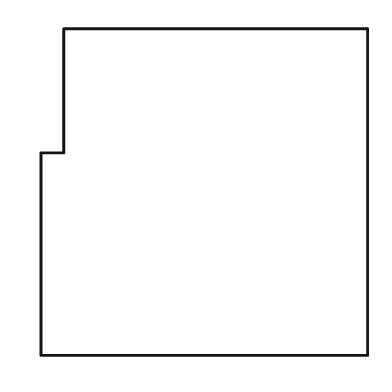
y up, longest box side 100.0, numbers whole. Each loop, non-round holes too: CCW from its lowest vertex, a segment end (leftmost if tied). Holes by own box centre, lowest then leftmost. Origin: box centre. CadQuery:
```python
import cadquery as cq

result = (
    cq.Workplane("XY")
    .moveTo(-50.0, -50.0)
    .lineTo(50.0, -50.0)
    .lineTo(50.0, 50.0)
    .lineTo(-43.0, 50.0)
    .lineTo(-43.0, 12.0)
    .lineTo(-50.0, 12.0)
    .close()
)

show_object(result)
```